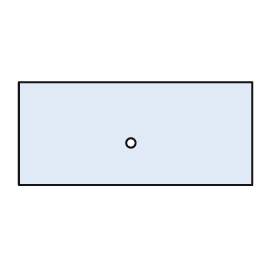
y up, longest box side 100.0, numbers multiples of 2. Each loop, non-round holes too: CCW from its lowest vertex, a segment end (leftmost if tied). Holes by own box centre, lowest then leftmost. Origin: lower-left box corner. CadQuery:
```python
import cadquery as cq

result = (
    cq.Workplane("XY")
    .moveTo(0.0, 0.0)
    .lineTo(100.0, 0.0)
    .lineTo(100.0, 44.0)
    .lineTo(0.0, 44.0)
    .close()
    .moveTo(48.0, 18.0)
    .circle(2.0)
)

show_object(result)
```